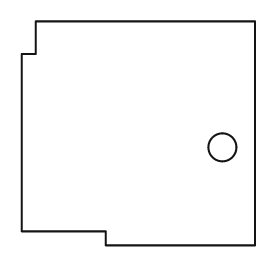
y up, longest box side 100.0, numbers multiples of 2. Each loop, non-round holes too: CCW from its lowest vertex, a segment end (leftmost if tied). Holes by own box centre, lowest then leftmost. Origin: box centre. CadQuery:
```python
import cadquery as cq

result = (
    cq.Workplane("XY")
    .moveTo(-14.0, -48.0)
    .lineTo(50.0, -48.0)
    .lineTo(50.0, 48.0)
    .lineTo(-44.0, 48.0)
    .lineTo(-44.0, 34.0)
    .lineTo(-50.0, 34.0)
    .lineTo(-50.0, -42.0)
    .lineTo(-14.0, -42.0)
    .close()
    .moveTo(36.0, -6.0)
    .circle(6.0)
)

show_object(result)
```